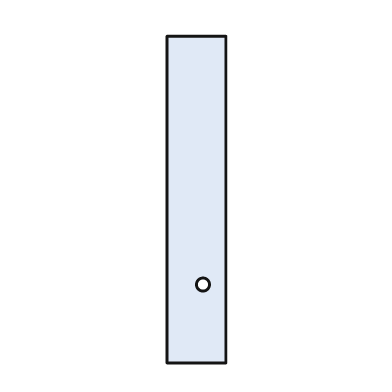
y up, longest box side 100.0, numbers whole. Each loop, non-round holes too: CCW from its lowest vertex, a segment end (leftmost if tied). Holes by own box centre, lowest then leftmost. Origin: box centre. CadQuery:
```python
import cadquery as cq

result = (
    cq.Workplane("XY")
    .moveTo(-9.0, -50.0)
    .lineTo(9.0, -50.0)
    .lineTo(9.0, 50.0)
    .lineTo(-9.0, 50.0)
    .close()
    .moveTo(2.0, -26.0)
    .circle(2.0)
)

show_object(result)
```